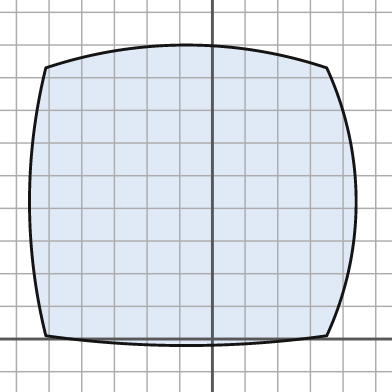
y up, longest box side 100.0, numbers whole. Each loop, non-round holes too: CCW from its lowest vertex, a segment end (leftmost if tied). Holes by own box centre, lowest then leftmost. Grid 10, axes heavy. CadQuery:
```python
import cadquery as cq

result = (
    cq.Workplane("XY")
    .moveTo(-51.0, 1.0)
    .threePointArc((-8.0, -2.0), (35.0, 1.0))
    .threePointArc((44.0, 42.0), (35.0, 83.0))
    .threePointArc((-8.0, 90.0), (-51.0, 83.0))
    .threePointArc((-56.0, 42.0), (-51.0, 1.0))
    .close()
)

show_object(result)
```